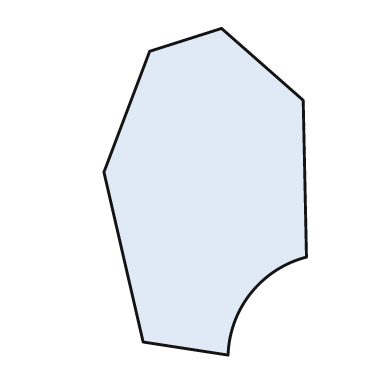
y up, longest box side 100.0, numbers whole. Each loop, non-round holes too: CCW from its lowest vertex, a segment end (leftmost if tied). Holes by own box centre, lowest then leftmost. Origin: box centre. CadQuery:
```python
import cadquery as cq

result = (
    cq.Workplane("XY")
    .moveTo(7.0, -50.0)
    .threePointArc((14.0, -31.0), (31.0, -20.0))
    .lineTo(30.0, 28.0)
    .lineTo(5.0, 50.0)
    .lineTo(-17.0, 43.0)
    .lineTo(-31.0, 6.0)
    .lineTo(-19.0, -46.0)
    .close()
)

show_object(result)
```